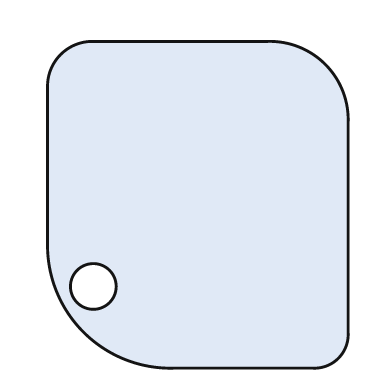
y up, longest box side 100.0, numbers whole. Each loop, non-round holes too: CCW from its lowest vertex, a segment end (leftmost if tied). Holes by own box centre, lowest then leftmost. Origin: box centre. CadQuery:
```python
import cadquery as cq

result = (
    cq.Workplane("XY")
    .moveTo(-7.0, -50.0)
    .lineTo(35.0, -50.0)
    .threePointArc((43.0, -47.0), (46.0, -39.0))
    .lineTo(46.0, 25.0)
    .threePointArc((39.0, 43.0), (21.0, 50.0))
    .lineTo(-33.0, 50.0)
    .threePointArc((-42.0, 46.0), (-46.0, 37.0))
    .lineTo(-46.0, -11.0)
    .threePointArc((-35.0, -39.0), (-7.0, -50.0))
    .close()
    .moveTo(-32.0, -25.0)
    .circle(7.0)
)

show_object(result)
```